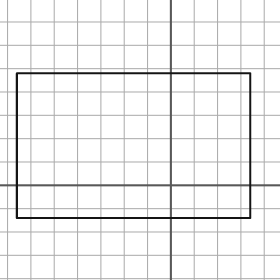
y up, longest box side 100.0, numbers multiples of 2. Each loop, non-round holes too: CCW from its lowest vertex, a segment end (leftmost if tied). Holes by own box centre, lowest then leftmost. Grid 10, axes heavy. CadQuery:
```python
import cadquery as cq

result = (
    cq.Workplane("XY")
    .moveTo(-66.0, -14.0)
    .lineTo(34.0, -14.0)
    .lineTo(34.0, 48.0)
    .lineTo(-66.0, 48.0)
    .close()
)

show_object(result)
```